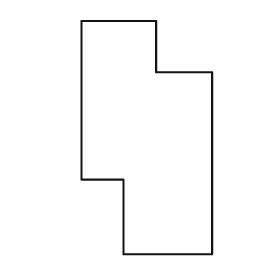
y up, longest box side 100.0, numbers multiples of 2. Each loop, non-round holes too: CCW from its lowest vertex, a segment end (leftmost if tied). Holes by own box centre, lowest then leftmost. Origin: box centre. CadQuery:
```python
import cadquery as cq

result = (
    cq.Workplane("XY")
    .moveTo(-10.0, -50.0)
    .lineTo(28.0, -50.0)
    .lineTo(28.0, 28.0)
    .lineTo(4.0, 28.0)
    .lineTo(4.0, 50.0)
    .lineTo(-28.0, 50.0)
    .lineTo(-28.0, -18.0)
    .lineTo(-10.0, -18.0)
    .close()
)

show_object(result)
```